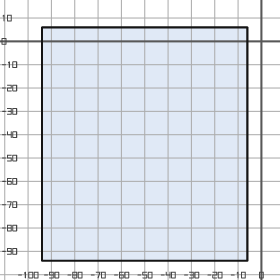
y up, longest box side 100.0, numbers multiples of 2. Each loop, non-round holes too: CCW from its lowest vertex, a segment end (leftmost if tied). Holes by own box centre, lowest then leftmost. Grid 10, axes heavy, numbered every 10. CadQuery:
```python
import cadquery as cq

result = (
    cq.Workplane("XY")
    .moveTo(-94.0, -94.0)
    .lineTo(-6.0, -94.0)
    .lineTo(-6.0, 6.0)
    .lineTo(-94.0, 6.0)
    .close()
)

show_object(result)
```